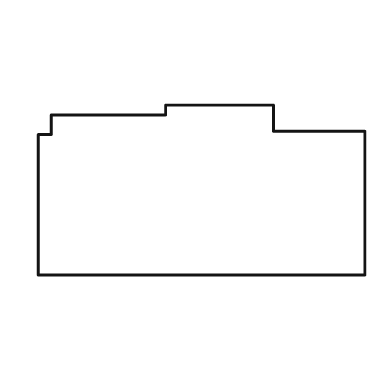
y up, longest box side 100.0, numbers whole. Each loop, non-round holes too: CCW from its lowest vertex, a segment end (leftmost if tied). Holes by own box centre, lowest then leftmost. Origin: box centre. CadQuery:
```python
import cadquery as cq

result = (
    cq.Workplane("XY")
    .moveTo(-50.0, -26.0)
    .lineTo(50.0, -26.0)
    .lineTo(50.0, 18.0)
    .lineTo(22.0, 18.0)
    .lineTo(22.0, 26.0)
    .lineTo(-11.0, 26.0)
    .lineTo(-11.0, 23.0)
    .lineTo(-46.0, 23.0)
    .lineTo(-46.0, 17.0)
    .lineTo(-50.0, 17.0)
    .close()
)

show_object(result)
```